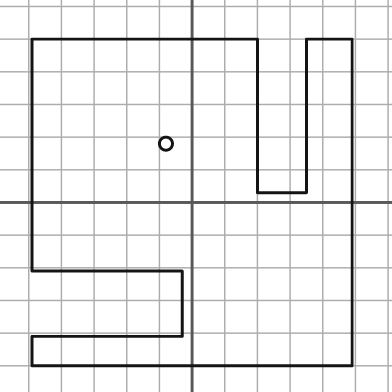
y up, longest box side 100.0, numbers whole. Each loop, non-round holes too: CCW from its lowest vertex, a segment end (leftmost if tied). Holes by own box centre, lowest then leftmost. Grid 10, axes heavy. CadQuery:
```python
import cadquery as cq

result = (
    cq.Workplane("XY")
    .moveTo(-49.0, -50.0)
    .lineTo(49.0, -50.0)
    .lineTo(49.0, 50.0)
    .lineTo(35.0, 50.0)
    .lineTo(35.0, 3.0)
    .lineTo(20.0, 3.0)
    .lineTo(20.0, 50.0)
    .lineTo(-49.0, 50.0)
    .lineTo(-49.0, -21.0)
    .lineTo(-3.0, -21.0)
    .lineTo(-3.0, -41.0)
    .lineTo(-49.0, -41.0)
    .close()
    .moveTo(-8.0, 18.0)
    .circle(2.0)
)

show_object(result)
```